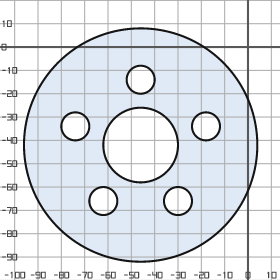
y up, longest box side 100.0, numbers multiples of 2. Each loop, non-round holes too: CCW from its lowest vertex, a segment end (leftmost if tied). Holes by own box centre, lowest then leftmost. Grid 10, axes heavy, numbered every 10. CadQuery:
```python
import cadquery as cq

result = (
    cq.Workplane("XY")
    .moveTo(-46.0, -42.0)
    .circle(50.0)
    .moveTo(-62.0, -66.0)
    .circle(6.0)
    .moveTo(-30.0, -66.0)
    .circle(6.0)
    .moveTo(-46.0, -42.0)
    .circle(16.0)
    .moveTo(-74.0, -34.0)
    .circle(6.0)
    .moveTo(-18.0, -34.0)
    .circle(6.0)
    .moveTo(-46.0, -14.0)
    .circle(6.0)
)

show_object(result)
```